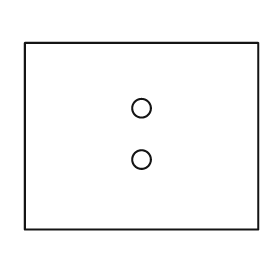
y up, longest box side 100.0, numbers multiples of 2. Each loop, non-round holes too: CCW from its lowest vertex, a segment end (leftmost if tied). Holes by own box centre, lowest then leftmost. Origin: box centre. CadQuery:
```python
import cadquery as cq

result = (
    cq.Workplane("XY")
    .moveTo(-50.0, -40.0)
    .lineTo(50.0, -40.0)
    .lineTo(50.0, 40.0)
    .lineTo(-50.0, 40.0)
    .close()
    .moveTo(0.0, -10.0)
    .circle(4.0)
    .moveTo(0.0, 12.0)
    .circle(4.0)
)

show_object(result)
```